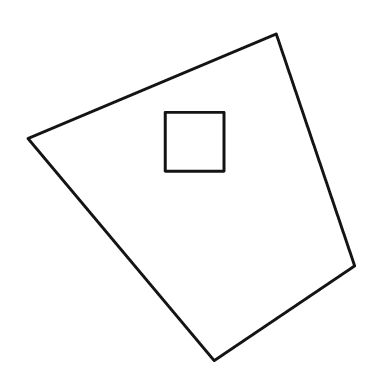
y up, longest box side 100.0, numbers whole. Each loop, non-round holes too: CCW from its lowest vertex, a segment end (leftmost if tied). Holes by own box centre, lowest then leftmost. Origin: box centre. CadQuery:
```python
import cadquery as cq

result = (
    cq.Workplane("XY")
    .moveTo(7.0, -50.0)
    .lineTo(50.0, -21.0)
    .lineTo(26.0, 50.0)
    .lineTo(-50.0, 18.0)
    .close()
    .moveTo(-8.0, 8.0)
    .lineTo(10.0, 8.0)
    .lineTo(10.0, 26.0)
    .lineTo(-8.0, 26.0)
    .close()
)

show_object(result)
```